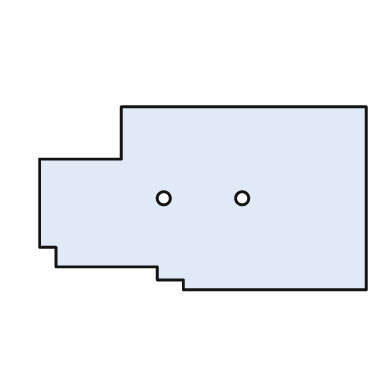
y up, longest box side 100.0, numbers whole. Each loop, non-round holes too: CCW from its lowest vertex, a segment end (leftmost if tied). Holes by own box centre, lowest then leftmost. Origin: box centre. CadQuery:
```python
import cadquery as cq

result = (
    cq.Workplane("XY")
    .moveTo(-6.0, -28.0)
    .lineTo(50.0, -28.0)
    .lineTo(50.0, 28.0)
    .lineTo(-25.0, 28.0)
    .lineTo(-25.0, 12.0)
    .lineTo(-50.0, 12.0)
    .lineTo(-50.0, -15.0)
    .lineTo(-45.0, -15.0)
    .lineTo(-45.0, -21.0)
    .lineTo(-14.0, -21.0)
    .lineTo(-14.0, -25.0)
    .lineTo(-6.0, -25.0)
    .close()
    .moveTo(-12.0, 0.0)
    .circle(2.0)
    .moveTo(12.0, 0.0)
    .circle(2.0)
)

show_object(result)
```